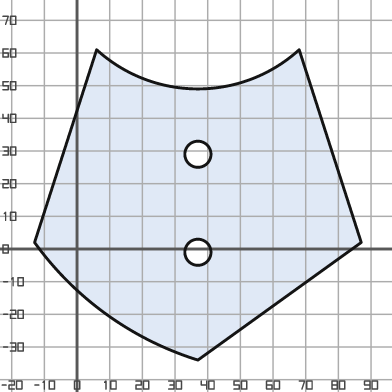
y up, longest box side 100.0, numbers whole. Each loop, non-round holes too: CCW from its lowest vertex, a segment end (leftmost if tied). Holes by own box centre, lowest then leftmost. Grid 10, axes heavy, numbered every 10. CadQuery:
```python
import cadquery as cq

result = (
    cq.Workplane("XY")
    .moveTo(37.0, -34.0)
    .lineTo(87.0, 2.0)
    .lineTo(68.0, 61.0)
    .threePointArc((37.0, 49.0), (6.0, 61.0))
    .lineTo(-13.0, 2.0)
    .threePointArc((9.0, -20.0), (37.0, -34.0))
    .close()
    .moveTo(37.0, -1.0)
    .circle(4.0)
    .moveTo(37.0, 29.0)
    .circle(4.0)
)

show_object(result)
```